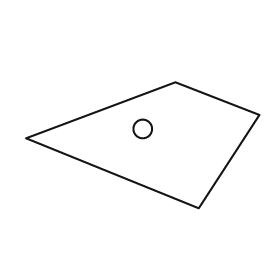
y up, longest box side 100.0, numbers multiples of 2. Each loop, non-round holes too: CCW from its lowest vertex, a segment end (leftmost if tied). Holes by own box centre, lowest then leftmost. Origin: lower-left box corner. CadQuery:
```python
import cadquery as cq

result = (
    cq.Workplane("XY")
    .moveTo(74.0, 0.0)
    .lineTo(100.0, 40.0)
    .lineTo(64.0, 54.0)
    .lineTo(0.0, 30.0)
    .close()
    .moveTo(50.0, 34.0)
    .circle(4.0)
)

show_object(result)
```